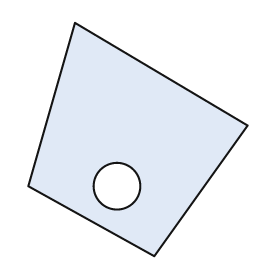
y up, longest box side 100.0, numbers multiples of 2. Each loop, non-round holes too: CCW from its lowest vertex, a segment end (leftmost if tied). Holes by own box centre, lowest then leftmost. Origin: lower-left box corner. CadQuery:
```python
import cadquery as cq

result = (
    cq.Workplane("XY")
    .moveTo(54.0, 0.0)
    .lineTo(94.0, 56.0)
    .lineTo(20.0, 100.0)
    .lineTo(0.0, 30.0)
    .close()
    .moveTo(38.0, 30.0)
    .circle(10.0)
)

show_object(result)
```